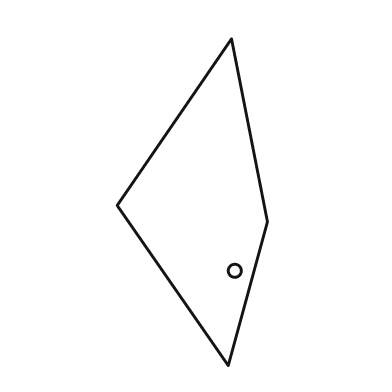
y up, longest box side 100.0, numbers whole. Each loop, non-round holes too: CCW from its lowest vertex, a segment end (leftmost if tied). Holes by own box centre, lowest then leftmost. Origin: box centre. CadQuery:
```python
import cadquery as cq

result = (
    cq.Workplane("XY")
    .moveTo(11.0, -50.0)
    .lineTo(23.0, -6.0)
    .lineTo(12.0, 50.0)
    .lineTo(-23.0, -1.0)
    .close()
    .moveTo(13.0, -21.0)
    .circle(2.0)
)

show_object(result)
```